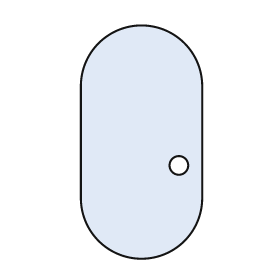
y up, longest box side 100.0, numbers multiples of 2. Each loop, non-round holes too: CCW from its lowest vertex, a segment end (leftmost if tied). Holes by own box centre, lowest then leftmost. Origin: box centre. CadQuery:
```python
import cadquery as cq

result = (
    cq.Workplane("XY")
    .moveTo(-26.0, -24.0)
    .threePointArc((0.0, -50.0), (26.0, -24.0))
    .lineTo(26.0, 24.0)
    .threePointArc((0.0, 50.0), (-26.0, 24.0))
    .close()
    .moveTo(16.0, -10.0)
    .circle(4.0)
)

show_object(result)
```